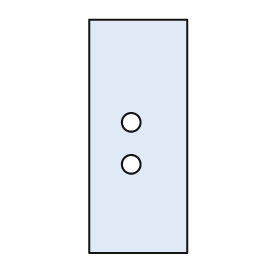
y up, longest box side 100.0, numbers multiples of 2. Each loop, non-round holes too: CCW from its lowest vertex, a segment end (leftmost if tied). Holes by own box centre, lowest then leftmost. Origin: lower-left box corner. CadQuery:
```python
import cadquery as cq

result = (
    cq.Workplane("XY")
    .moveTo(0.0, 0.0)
    .lineTo(42.0, 0.0)
    .lineTo(42.0, 100.0)
    .lineTo(0.0, 100.0)
    .close()
    .moveTo(18.0, 38.0)
    .circle(4.0)
    .moveTo(18.0, 56.0)
    .circle(4.0)
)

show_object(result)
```